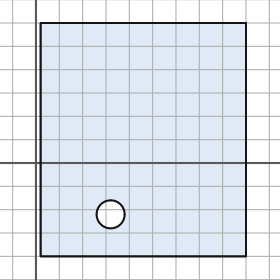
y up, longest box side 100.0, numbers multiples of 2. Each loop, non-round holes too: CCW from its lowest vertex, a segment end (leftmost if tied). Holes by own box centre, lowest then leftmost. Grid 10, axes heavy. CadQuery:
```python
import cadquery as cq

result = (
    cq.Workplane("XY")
    .moveTo(2.0, -40.0)
    .lineTo(90.0, -40.0)
    .lineTo(90.0, 60.0)
    .lineTo(2.0, 60.0)
    .close()
    .moveTo(32.0, -22.0)
    .circle(6.0)
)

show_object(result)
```